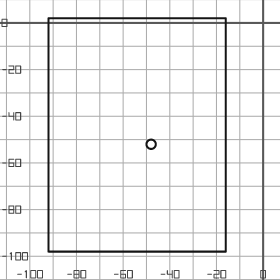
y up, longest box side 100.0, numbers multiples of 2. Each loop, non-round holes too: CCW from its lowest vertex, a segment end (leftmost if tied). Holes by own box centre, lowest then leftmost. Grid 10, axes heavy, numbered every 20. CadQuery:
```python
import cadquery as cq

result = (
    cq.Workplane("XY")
    .moveTo(-92.0, -98.0)
    .lineTo(-16.0, -98.0)
    .lineTo(-16.0, 2.0)
    .lineTo(-92.0, 2.0)
    .close()
    .moveTo(-48.0, -52.0)
    .circle(2.0)
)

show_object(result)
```